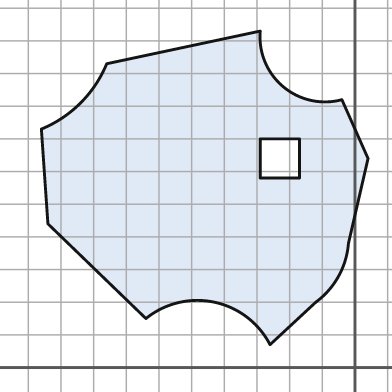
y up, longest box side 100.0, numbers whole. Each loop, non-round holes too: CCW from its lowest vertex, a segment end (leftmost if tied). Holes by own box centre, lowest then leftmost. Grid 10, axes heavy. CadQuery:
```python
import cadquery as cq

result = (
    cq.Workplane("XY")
    .moveTo(-26.0, 7.0)
    .lineTo(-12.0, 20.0)
    .threePointArc((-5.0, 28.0), (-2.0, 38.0))
    .lineTo(4.0, 64.0)
    .lineTo(-4.0, 82.0)
    .threePointArc((-22.0, 86.0), (-29.0, 103.0))
    .lineTo(-76.0, 93.0)
    .threePointArc((-84.0, 81.0), (-96.0, 73.0))
    .lineTo(-94.0, 44.0)
    .lineTo(-64.0, 15.0)
    .threePointArc((-43.0, 20.0), (-26.0, 7.0))
    .close()
    .moveTo(-29.0, 58.0)
    .lineTo(-17.0, 58.0)
    .lineTo(-17.0, 70.0)
    .lineTo(-29.0, 70.0)
    .close()
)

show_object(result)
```